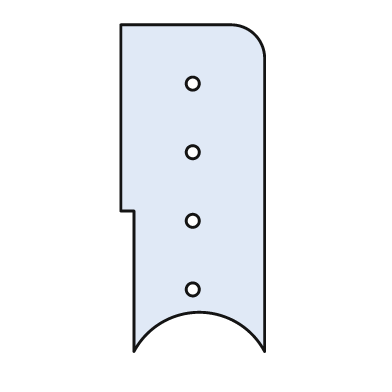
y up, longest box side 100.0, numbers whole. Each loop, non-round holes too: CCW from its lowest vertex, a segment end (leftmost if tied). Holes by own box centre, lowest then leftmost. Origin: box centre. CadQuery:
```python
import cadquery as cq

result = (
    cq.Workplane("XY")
    .moveTo(-18.0, -50.0)
    .threePointArc((2.0, -38.0), (22.0, -50.0))
    .lineTo(22.0, 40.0)
    .threePointArc((19.0, 47.0), (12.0, 50.0))
    .lineTo(-22.0, 50.0)
    .lineTo(-22.0, -7.0)
    .lineTo(-18.0, -7.0)
    .close()
    .moveTo(0.0, -31.0)
    .circle(2.0)
    .moveTo(0.0, -10.0)
    .circle(2.0)
    .moveTo(0.0, 11.0)
    .circle(2.0)
    .moveTo(0.0, 32.0)
    .circle(2.0)
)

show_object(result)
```